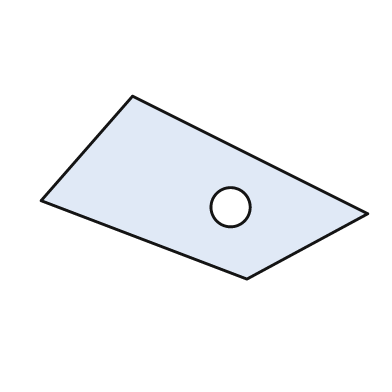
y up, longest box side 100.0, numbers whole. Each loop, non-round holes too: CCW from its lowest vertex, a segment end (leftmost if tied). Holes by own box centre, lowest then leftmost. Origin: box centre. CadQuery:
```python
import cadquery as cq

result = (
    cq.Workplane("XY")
    .moveTo(13.0, -28.0)
    .lineTo(50.0, -8.0)
    .lineTo(-22.0, 28.0)
    .lineTo(-50.0, -4.0)
    .close()
    .moveTo(8.0, -6.0)
    .circle(6.0)
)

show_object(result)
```